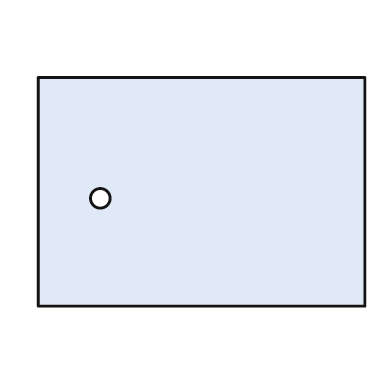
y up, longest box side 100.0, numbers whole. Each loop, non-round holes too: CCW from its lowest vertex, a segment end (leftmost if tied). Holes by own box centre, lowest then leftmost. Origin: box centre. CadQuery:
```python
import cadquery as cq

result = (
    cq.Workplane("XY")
    .moveTo(-50.0, -35.0)
    .lineTo(50.0, -35.0)
    .lineTo(50.0, 35.0)
    .lineTo(-50.0, 35.0)
    .close()
    .moveTo(-31.0, -2.0)
    .circle(3.0)
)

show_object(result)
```